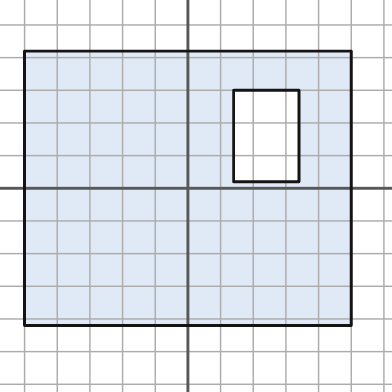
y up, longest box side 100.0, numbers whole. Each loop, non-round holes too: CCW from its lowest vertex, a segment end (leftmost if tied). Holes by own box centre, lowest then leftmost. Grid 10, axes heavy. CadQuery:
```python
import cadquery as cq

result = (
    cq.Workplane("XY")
    .moveTo(-50.0, -42.0)
    .lineTo(50.0, -42.0)
    .lineTo(50.0, 42.0)
    .lineTo(-50.0, 42.0)
    .close()
    .moveTo(14.0, 2.0)
    .lineTo(34.0, 2.0)
    .lineTo(34.0, 30.0)
    .lineTo(14.0, 30.0)
    .close()
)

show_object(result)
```